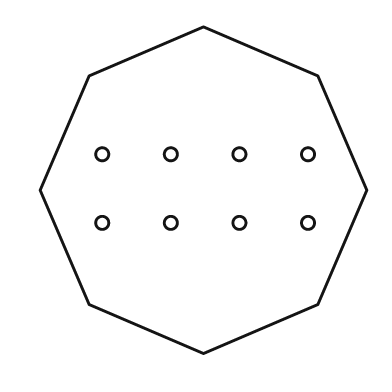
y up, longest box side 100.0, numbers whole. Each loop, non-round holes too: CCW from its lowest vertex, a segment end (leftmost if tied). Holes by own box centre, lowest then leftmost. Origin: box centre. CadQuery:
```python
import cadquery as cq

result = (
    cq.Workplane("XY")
    .moveTo(0.0, -50.0)
    .lineTo(35.0, -35.0)
    .lineTo(50.0, 0.0)
    .lineTo(35.0, 35.0)
    .lineTo(0.0, 50.0)
    .lineTo(-35.0, 35.0)
    .lineTo(-50.0, 0.0)
    .lineTo(-35.0, -35.0)
    .close()
    .moveTo(-31.0, -10.0)
    .circle(2.0)
    .moveTo(-10.0, -10.0)
    .circle(2.0)
    .moveTo(11.0, -10.0)
    .circle(2.0)
    .moveTo(32.0, -10.0)
    .circle(2.0)
    .moveTo(-31.0, 11.0)
    .circle(2.0)
    .moveTo(-10.0, 11.0)
    .circle(2.0)
    .moveTo(11.0, 11.0)
    .circle(2.0)
    .moveTo(32.0, 11.0)
    .circle(2.0)
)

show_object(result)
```